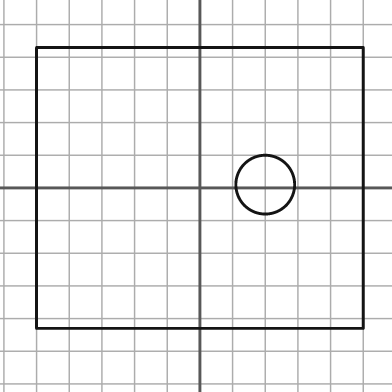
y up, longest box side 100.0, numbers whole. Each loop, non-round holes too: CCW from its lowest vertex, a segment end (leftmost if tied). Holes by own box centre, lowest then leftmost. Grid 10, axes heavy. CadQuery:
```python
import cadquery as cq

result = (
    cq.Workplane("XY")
    .moveTo(-50.0, -43.0)
    .lineTo(50.0, -43.0)
    .lineTo(50.0, 43.0)
    .lineTo(-50.0, 43.0)
    .close()
    .moveTo(20.0, 1.0)
    .circle(9.0)
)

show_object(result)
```